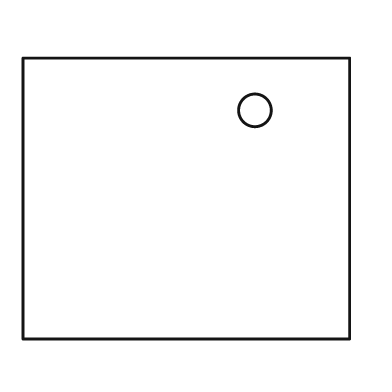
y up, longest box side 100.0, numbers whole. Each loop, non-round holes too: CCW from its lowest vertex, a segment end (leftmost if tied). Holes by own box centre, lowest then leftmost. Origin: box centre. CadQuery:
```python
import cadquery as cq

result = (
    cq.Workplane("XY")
    .moveTo(-50.0, -43.0)
    .lineTo(50.0, -43.0)
    .lineTo(50.0, 43.0)
    .lineTo(-50.0, 43.0)
    .close()
    .moveTo(21.0, 27.0)
    .circle(5.0)
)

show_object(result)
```